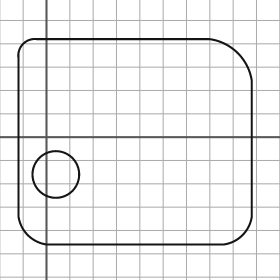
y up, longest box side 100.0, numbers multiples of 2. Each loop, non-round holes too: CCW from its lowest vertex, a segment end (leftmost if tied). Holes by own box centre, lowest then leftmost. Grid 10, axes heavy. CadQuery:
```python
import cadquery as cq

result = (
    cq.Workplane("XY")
    .moveTo(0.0, -46.0)
    .lineTo(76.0, -46.0)
    .threePointArc((84.0, -42.0), (88.0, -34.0))
    .lineTo(88.0, 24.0)
    .threePointArc((82.0, 36.0), (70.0, 42.0))
    .lineTo(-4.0, 42.0)
    .threePointArc((-10.0, 40.0), (-12.0, 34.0))
    .lineTo(-12.0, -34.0)
    .threePointArc((-8.0, -42.0), (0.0, -46.0))
    .close()
    .moveTo(4.0, -16.0)
    .circle(10.0)
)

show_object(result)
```